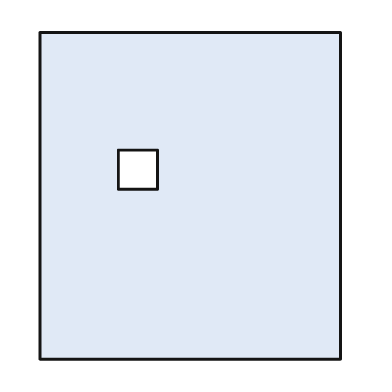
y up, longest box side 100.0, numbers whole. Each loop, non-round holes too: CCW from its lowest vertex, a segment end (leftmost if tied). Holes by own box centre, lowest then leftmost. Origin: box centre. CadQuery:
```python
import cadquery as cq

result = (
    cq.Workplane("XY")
    .moveTo(-46.0, -50.0)
    .lineTo(46.0, -50.0)
    .lineTo(46.0, 50.0)
    .lineTo(-46.0, 50.0)
    .close()
    .moveTo(-22.0, 2.0)
    .lineTo(-10.0, 2.0)
    .lineTo(-10.0, 14.0)
    .lineTo(-22.0, 14.0)
    .close()
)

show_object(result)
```